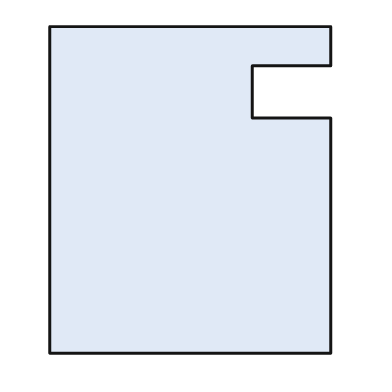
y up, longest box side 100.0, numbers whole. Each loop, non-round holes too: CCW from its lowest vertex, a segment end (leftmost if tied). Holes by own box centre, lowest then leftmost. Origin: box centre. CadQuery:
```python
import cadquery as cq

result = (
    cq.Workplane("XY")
    .moveTo(-43.0, -50.0)
    .lineTo(43.0, -50.0)
    .lineTo(43.0, 22.0)
    .lineTo(19.0, 22.0)
    .lineTo(19.0, 38.0)
    .lineTo(43.0, 38.0)
    .lineTo(43.0, 50.0)
    .lineTo(-43.0, 50.0)
    .close()
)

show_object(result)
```